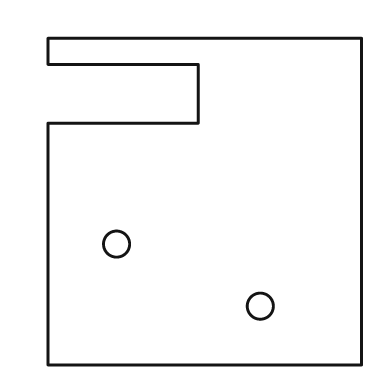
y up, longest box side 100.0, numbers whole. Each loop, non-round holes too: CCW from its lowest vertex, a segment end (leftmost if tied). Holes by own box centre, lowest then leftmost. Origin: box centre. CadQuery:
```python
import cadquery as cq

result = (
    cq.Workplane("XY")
    .moveTo(-48.0, -50.0)
    .lineTo(48.0, -50.0)
    .lineTo(48.0, 50.0)
    .lineTo(-48.0, 50.0)
    .lineTo(-48.0, 42.0)
    .lineTo(-2.0, 42.0)
    .lineTo(-2.0, 24.0)
    .lineTo(-48.0, 24.0)
    .close()
    .moveTo(17.0, -32.0)
    .circle(4.0)
    .moveTo(-27.0, -13.0)
    .circle(4.0)
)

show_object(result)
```